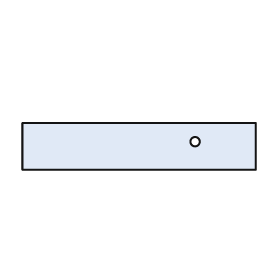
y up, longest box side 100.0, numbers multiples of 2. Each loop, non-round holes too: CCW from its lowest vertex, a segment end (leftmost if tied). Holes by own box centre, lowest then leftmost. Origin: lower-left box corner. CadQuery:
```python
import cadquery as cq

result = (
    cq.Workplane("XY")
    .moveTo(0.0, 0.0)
    .lineTo(100.0, 0.0)
    .lineTo(100.0, 20.0)
    .lineTo(0.0, 20.0)
    .close()
    .moveTo(74.0, 12.0)
    .circle(2.0)
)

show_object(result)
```